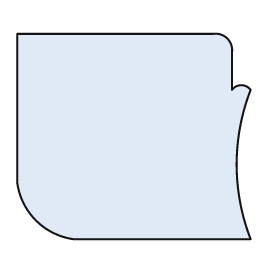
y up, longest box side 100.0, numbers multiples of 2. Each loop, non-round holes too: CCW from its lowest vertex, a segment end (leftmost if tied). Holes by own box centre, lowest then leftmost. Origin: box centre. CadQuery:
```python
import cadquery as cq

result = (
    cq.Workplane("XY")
    .moveTo(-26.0, -44.0)
    .lineTo(50.0, -44.0)
    .threePointArc((44.0, -12.0), (50.0, 20.0))
    .threePointArc((46.0, 22.0), (42.0, 20.0))
    .lineTo(42.0, 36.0)
    .threePointArc((40.0, 42.0), (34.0, 44.0))
    .lineTo(-50.0, 44.0)
    .lineTo(-50.0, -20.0)
    .threePointArc((-42.0, -36.0), (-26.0, -44.0))
    .close()
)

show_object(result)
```